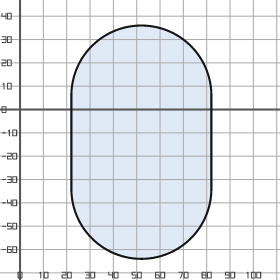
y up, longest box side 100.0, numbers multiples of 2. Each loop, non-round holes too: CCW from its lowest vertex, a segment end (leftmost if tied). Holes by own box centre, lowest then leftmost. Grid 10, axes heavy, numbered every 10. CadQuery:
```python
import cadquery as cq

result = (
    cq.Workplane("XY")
    .moveTo(22.0, -34.0)
    .threePointArc((52.0, -64.0), (82.0, -34.0))
    .lineTo(82.0, 6.0)
    .threePointArc((52.0, 36.0), (22.0, 6.0))
    .close()
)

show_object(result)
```